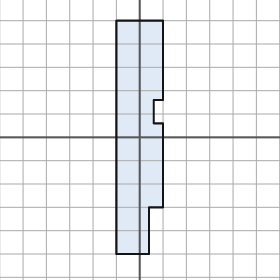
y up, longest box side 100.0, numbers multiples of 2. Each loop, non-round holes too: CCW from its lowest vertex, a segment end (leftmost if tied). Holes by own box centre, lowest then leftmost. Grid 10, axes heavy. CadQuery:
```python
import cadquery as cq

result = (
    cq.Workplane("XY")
    .moveTo(-10.0, -50.0)
    .lineTo(4.0, -50.0)
    .lineTo(4.0, -30.0)
    .lineTo(10.0, -30.0)
    .lineTo(10.0, 6.0)
    .lineTo(6.0, 6.0)
    .lineTo(6.0, 16.0)
    .lineTo(10.0, 16.0)
    .lineTo(10.0, 50.0)
    .lineTo(-10.0, 50.0)
    .close()
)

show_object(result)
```